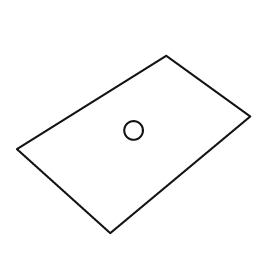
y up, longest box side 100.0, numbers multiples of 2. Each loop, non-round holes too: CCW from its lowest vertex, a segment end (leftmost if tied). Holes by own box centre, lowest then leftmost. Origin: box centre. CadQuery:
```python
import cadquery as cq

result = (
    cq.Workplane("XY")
    .moveTo(-10.0, -38.0)
    .lineTo(50.0, 12.0)
    .lineTo(14.0, 38.0)
    .lineTo(-50.0, -2.0)
    .close()
    .moveTo(0.0, 6.0)
    .circle(4.0)
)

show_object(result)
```